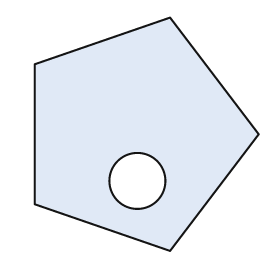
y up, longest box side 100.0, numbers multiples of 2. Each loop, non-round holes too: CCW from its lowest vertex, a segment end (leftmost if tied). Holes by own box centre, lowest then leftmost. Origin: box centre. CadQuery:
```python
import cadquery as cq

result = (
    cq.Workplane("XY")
    .moveTo(10.0, -50.0)
    .lineTo(48.0, 0.0)
    .lineTo(10.0, 50.0)
    .lineTo(-48.0, 30.0)
    .lineTo(-48.0, -30.0)
    .close()
    .moveTo(-4.0, -20.0)
    .circle(12.0)
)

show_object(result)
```